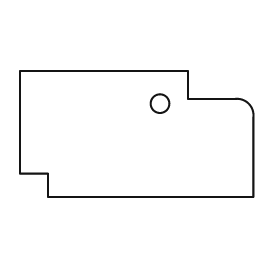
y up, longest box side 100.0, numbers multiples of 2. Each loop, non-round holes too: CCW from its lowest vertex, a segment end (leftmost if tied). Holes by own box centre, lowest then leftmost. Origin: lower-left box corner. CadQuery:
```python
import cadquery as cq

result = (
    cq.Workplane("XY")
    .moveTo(12.0, 0.0)
    .lineTo(100.0, 0.0)
    .lineTo(100.0, 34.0)
    .threePointArc((98.0, 40.0), (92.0, 42.0))
    .lineTo(72.0, 42.0)
    .lineTo(72.0, 54.0)
    .lineTo(0.0, 54.0)
    .lineTo(0.0, 10.0)
    .lineTo(12.0, 10.0)
    .close()
    .moveTo(60.0, 40.0)
    .circle(4.0)
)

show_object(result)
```